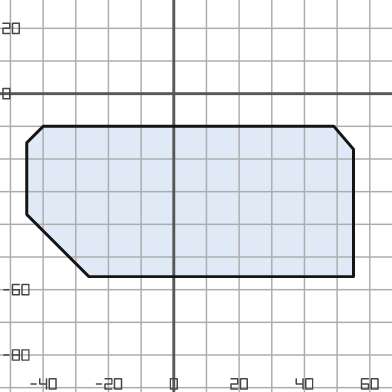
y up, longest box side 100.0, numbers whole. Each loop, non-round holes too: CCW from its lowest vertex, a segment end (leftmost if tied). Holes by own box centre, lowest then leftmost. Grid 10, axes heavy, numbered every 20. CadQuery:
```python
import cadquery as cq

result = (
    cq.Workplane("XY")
    .moveTo(-26.0, -56.0)
    .lineTo(55.0, -56.0)
    .lineTo(55.0, -17.0)
    .lineTo(49.0, -10.0)
    .lineTo(-40.0, -10.0)
    .lineTo(-45.0, -15.0)
    .lineTo(-45.0, -37.0)
    .close()
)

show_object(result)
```